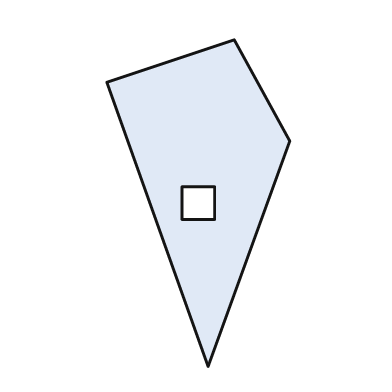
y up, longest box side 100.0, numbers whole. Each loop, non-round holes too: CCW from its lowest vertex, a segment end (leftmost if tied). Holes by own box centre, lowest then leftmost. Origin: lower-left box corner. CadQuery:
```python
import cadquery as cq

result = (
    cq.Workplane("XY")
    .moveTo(31.0, 0.0)
    .lineTo(56.0, 69.0)
    .lineTo(39.0, 100.0)
    .lineTo(0.0, 87.0)
    .close()
    .moveTo(23.0, 45.0)
    .lineTo(33.0, 45.0)
    .lineTo(33.0, 55.0)
    .lineTo(23.0, 55.0)
    .close()
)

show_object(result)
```